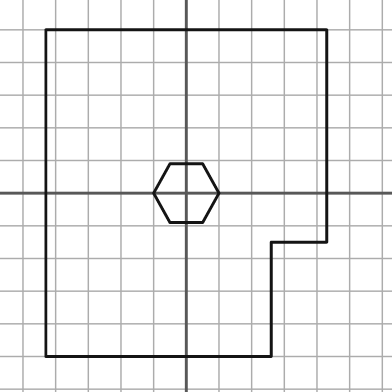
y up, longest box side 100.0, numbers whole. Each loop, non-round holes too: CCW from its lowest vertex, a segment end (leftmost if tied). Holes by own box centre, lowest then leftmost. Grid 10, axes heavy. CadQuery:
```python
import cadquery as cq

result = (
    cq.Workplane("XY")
    .moveTo(-43.0, -50.0)
    .lineTo(26.0, -50.0)
    .lineTo(26.0, -15.0)
    .lineTo(43.0, -15.0)
    .lineTo(43.0, 50.0)
    .lineTo(-43.0, 50.0)
    .close()
    .moveTo(-5.0, -9.0)
    .lineTo(5.0, -9.0)
    .lineTo(10.0, 0.0)
    .lineTo(5.0, 9.0)
    .lineTo(-5.0, 9.0)
    .lineTo(-10.0, 0.0)
    .close()
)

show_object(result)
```